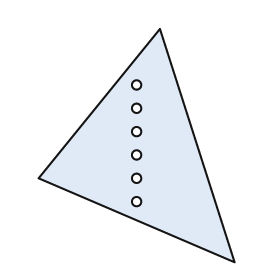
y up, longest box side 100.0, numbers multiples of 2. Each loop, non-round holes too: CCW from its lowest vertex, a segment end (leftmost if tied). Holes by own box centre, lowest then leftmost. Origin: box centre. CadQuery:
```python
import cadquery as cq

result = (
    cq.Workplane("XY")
    .moveTo(42.0, -50.0)
    .lineTo(10.0, 50.0)
    .lineTo(-42.0, -14.0)
    .close()
    .moveTo(0.0, -24.0)
    .circle(2.0)
    .moveTo(0.0, -14.0)
    .circle(2.0)
    .moveTo(0.0, -4.0)
    .circle(2.0)
    .moveTo(0.0, 6.0)
    .circle(2.0)
    .moveTo(0.0, 16.0)
    .circle(2.0)
    .moveTo(0.0, 26.0)
    .circle(2.0)
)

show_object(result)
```